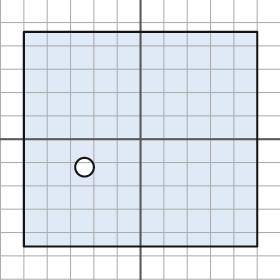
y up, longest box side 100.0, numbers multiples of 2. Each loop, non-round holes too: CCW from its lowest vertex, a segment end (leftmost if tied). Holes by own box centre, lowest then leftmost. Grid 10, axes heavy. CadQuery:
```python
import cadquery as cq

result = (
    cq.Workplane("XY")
    .moveTo(-50.0, -46.0)
    .lineTo(50.0, -46.0)
    .lineTo(50.0, 46.0)
    .lineTo(-50.0, 46.0)
    .close()
    .moveTo(-24.0, -12.0)
    .circle(4.0)
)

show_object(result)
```